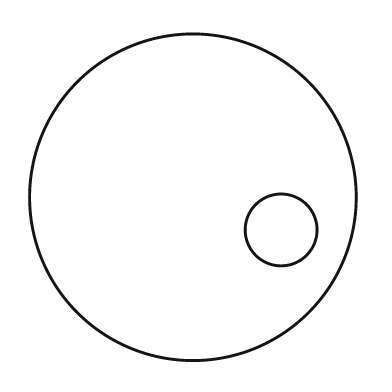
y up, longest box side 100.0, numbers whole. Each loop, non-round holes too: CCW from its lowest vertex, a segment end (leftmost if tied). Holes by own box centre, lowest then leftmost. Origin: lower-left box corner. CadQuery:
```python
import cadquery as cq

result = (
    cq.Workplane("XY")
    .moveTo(50.0, 50.0)
    .circle(50.0)
    .moveTo(77.0, 40.0)
    .circle(11.0)
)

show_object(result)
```